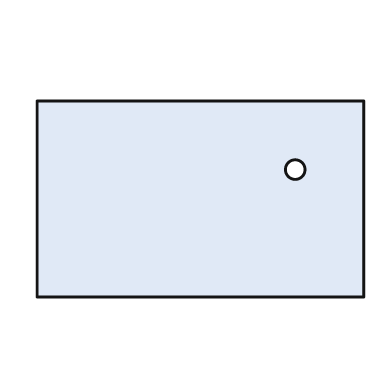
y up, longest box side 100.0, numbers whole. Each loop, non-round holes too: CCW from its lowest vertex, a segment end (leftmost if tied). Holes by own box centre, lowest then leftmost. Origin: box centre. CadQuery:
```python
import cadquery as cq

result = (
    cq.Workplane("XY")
    .moveTo(-50.0, -30.0)
    .lineTo(50.0, -30.0)
    .lineTo(50.0, 30.0)
    .lineTo(-50.0, 30.0)
    .close()
    .moveTo(29.0, 9.0)
    .circle(3.0)
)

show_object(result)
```